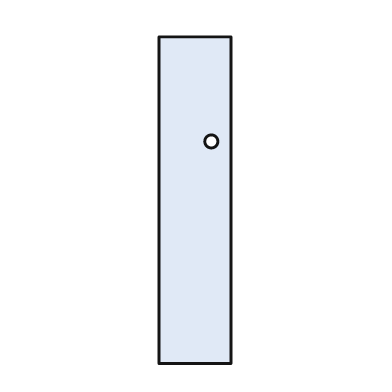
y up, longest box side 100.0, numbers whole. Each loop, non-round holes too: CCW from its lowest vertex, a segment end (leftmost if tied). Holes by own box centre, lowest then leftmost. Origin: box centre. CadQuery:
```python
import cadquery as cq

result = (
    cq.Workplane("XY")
    .moveTo(-11.0, -50.0)
    .lineTo(11.0, -50.0)
    .lineTo(11.0, 50.0)
    .lineTo(-11.0, 50.0)
    .close()
    .moveTo(5.0, 18.0)
    .circle(2.0)
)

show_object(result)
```